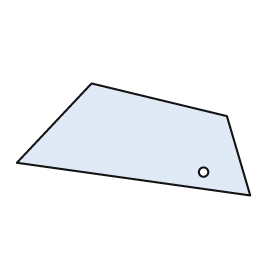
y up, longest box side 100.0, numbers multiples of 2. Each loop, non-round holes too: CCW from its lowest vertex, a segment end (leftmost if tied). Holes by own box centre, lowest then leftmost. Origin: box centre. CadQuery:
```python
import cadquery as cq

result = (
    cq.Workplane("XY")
    .moveTo(50.0, -24.0)
    .lineTo(40.0, 10.0)
    .lineTo(-18.0, 24.0)
    .lineTo(-50.0, -10.0)
    .close()
    .moveTo(30.0, -14.0)
    .circle(2.0)
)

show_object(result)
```